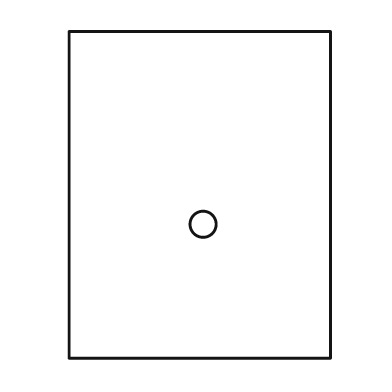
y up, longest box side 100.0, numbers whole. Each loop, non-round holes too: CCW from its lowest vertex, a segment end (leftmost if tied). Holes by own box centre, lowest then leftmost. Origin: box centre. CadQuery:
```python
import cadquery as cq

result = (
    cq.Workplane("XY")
    .moveTo(-40.0, -50.0)
    .lineTo(40.0, -50.0)
    .lineTo(40.0, 50.0)
    .lineTo(-40.0, 50.0)
    .close()
    .moveTo(1.0, -9.0)
    .circle(4.0)
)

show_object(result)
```